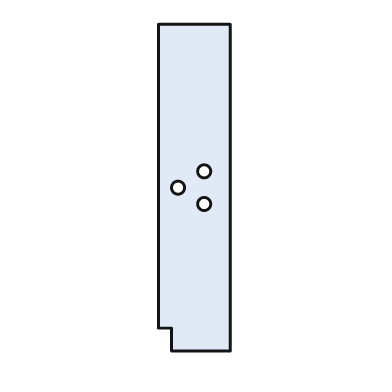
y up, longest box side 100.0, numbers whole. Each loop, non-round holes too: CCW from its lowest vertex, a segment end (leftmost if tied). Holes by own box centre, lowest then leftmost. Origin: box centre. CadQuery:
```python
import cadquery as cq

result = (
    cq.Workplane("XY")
    .moveTo(-7.0, -50.0)
    .lineTo(11.0, -50.0)
    .lineTo(11.0, 50.0)
    .lineTo(-11.0, 50.0)
    .lineTo(-11.0, -43.0)
    .lineTo(-7.0, -43.0)
    .close()
    .moveTo(3.0, -5.0)
    .circle(2.0)
    .moveTo(-5.0, 0.0)
    .circle(2.0)
    .moveTo(3.0, 5.0)
    .circle(2.0)
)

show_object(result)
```